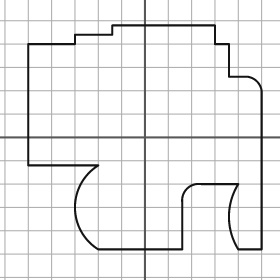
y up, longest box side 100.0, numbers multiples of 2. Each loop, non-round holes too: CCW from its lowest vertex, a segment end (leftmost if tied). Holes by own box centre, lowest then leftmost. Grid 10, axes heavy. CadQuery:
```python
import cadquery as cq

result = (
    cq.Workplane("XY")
    .moveTo(-20.0, -48.0)
    .lineTo(16.0, -48.0)
    .lineTo(16.0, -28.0)
    .threePointArc((18.0, -22.0), (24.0, -20.0))
    .lineTo(40.0, -20.0)
    .threePointArc((36.0, -34.0), (40.0, -48.0))
    .lineTo(50.0, -48.0)
    .lineTo(50.0, 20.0)
    .threePointArc((48.0, 24.0), (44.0, 26.0))
    .lineTo(36.0, 26.0)
    .lineTo(36.0, 40.0)
    .lineTo(30.0, 40.0)
    .lineTo(30.0, 48.0)
    .lineTo(-14.0, 48.0)
    .lineTo(-14.0, 44.0)
    .lineTo(-30.0, 44.0)
    .lineTo(-30.0, 40.0)
    .lineTo(-50.0, 40.0)
    .lineTo(-50.0, -12.0)
    .lineTo(-20.0, -12.0)
    .threePointArc((-30.0, -30.0), (-20.0, -48.0))
    .close()
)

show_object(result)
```